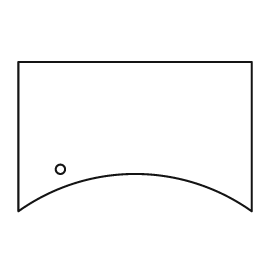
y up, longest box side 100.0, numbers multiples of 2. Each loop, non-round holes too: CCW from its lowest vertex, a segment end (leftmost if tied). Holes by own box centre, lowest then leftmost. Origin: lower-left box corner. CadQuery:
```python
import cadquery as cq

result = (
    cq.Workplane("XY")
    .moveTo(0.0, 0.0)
    .threePointArc((50.0, 16.0), (100.0, 0.0))
    .lineTo(100.0, 64.0)
    .lineTo(0.0, 64.0)
    .close()
    .moveTo(18.0, 18.0)
    .circle(2.0)
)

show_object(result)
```